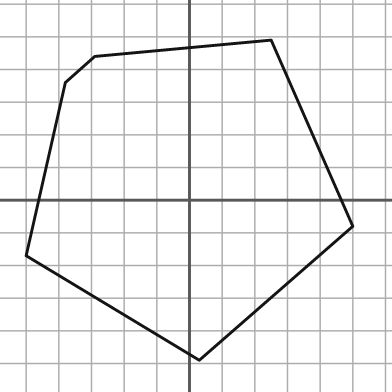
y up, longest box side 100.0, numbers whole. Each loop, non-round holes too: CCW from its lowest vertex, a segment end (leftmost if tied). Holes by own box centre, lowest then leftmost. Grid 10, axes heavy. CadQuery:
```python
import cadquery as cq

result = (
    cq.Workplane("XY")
    .moveTo(3.0, -49.0)
    .lineTo(50.0, -8.0)
    .lineTo(25.0, 49.0)
    .lineTo(-29.0, 44.0)
    .lineTo(-38.0, 36.0)
    .lineTo(-50.0, -17.0)
    .close()
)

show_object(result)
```